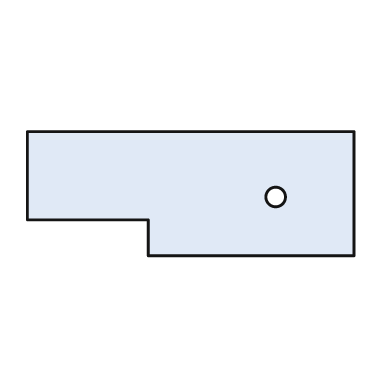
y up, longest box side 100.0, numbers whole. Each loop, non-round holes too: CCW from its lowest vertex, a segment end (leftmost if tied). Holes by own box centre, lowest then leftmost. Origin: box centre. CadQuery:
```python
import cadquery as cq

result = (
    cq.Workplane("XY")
    .moveTo(-13.0, -19.0)
    .lineTo(50.0, -19.0)
    .lineTo(50.0, 19.0)
    .lineTo(-50.0, 19.0)
    .lineTo(-50.0, -8.0)
    .lineTo(-13.0, -8.0)
    .close()
    .moveTo(26.0, -1.0)
    .circle(3.0)
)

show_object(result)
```